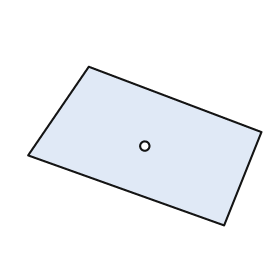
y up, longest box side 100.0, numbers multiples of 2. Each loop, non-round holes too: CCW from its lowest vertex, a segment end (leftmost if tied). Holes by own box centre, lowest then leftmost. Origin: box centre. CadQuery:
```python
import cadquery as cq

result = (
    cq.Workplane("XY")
    .moveTo(34.0, -34.0)
    .lineTo(50.0, 6.0)
    .lineTo(-24.0, 34.0)
    .lineTo(-50.0, -4.0)
    .close()
    .moveTo(0.0, 0.0)
    .circle(2.0)
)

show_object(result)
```